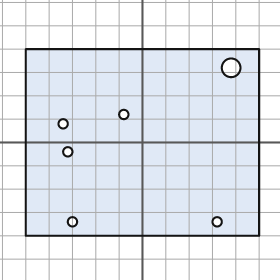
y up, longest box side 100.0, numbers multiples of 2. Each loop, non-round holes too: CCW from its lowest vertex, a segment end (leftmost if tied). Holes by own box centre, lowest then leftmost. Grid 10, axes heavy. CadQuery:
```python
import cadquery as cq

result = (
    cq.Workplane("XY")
    .moveTo(-50.0, -40.0)
    .lineTo(50.0, -40.0)
    .lineTo(50.0, 40.0)
    .lineTo(-50.0, 40.0)
    .close()
    .moveTo(-30.0, -34.0)
    .circle(2.0)
    .moveTo(32.0, -34.0)
    .circle(2.0)
    .moveTo(-32.0, -4.0)
    .circle(2.0)
    .moveTo(-34.0, 8.0)
    .circle(2.0)
    .moveTo(-8.0, 12.0)
    .circle(2.0)
    .moveTo(38.0, 32.0)
    .circle(4.0)
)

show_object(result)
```